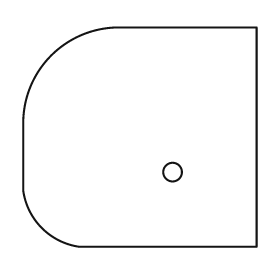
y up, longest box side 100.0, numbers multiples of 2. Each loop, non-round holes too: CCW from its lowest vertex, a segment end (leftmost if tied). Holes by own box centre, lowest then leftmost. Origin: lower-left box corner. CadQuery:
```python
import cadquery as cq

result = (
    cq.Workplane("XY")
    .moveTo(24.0, 0.0)
    .lineTo(100.0, 0.0)
    .lineTo(100.0, 94.0)
    .lineTo(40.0, 94.0)
    .threePointArc((12.0, 82.0), (0.0, 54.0))
    .lineTo(0.0, 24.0)
    .threePointArc((8.0, 8.0), (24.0, 0.0))
    .close()
    .moveTo(64.0, 32.0)
    .circle(4.0)
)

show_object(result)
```